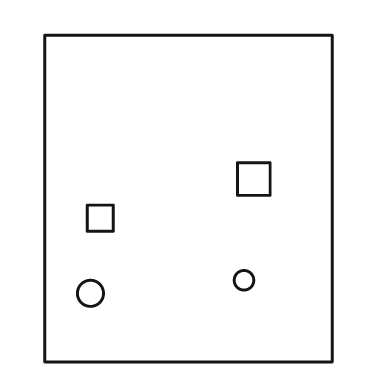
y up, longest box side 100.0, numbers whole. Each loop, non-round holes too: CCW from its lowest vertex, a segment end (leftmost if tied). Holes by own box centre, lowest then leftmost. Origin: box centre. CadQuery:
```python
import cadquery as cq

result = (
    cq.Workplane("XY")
    .moveTo(-44.0, -50.0)
    .lineTo(44.0, -50.0)
    .lineTo(44.0, 50.0)
    .lineTo(-44.0, 50.0)
    .close()
    .moveTo(-30.0, -29.0)
    .circle(4.0)
    .moveTo(17.0, -25.0)
    .circle(3.0)
    .moveTo(-31.0, -10.0)
    .lineTo(-23.0, -10.0)
    .lineTo(-23.0, -2.0)
    .lineTo(-31.0, -2.0)
    .close()
    .moveTo(15.0, 1.0)
    .lineTo(25.0, 1.0)
    .lineTo(25.0, 11.0)
    .lineTo(15.0, 11.0)
    .close()
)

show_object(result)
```